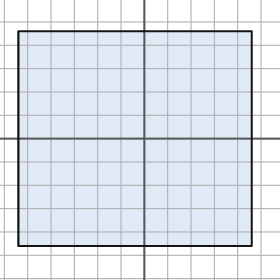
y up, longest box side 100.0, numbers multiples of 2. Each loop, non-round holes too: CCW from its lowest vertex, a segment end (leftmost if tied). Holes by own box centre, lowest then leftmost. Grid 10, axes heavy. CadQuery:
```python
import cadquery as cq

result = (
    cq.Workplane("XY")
    .moveTo(-54.0, -46.0)
    .lineTo(46.0, -46.0)
    .lineTo(46.0, 46.0)
    .lineTo(-54.0, 46.0)
    .close()
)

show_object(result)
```